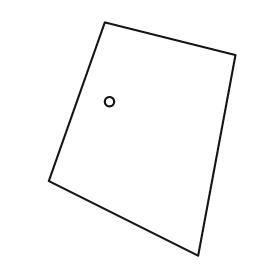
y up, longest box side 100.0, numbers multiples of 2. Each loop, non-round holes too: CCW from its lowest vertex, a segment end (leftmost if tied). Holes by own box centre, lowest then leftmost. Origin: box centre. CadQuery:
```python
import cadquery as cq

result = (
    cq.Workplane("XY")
    .moveTo(24.0, -50.0)
    .lineTo(40.0, 36.0)
    .lineTo(-16.0, 50.0)
    .lineTo(-40.0, -18.0)
    .close()
    .moveTo(-14.0, 16.0)
    .circle(2.0)
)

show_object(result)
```